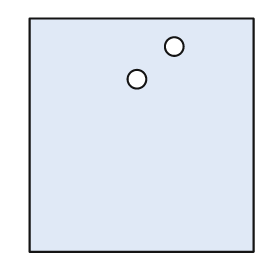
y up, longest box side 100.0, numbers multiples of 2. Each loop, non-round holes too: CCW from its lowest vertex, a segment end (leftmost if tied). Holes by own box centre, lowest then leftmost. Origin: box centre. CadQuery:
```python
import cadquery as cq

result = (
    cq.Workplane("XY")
    .moveTo(-48.0, -50.0)
    .lineTo(48.0, -50.0)
    .lineTo(48.0, 50.0)
    .lineTo(-48.0, 50.0)
    .close()
    .moveTo(-2.0, 24.0)
    .circle(4.0)
    .moveTo(14.0, 38.0)
    .circle(4.0)
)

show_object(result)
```